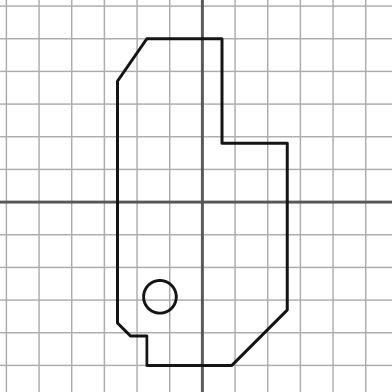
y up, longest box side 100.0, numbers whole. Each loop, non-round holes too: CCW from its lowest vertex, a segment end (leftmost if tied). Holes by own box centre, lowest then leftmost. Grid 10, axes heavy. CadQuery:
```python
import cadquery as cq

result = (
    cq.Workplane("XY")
    .moveTo(-17.0, -50.0)
    .lineTo(9.0, -50.0)
    .lineTo(26.0, -33.0)
    .lineTo(26.0, 18.0)
    .lineTo(6.0, 18.0)
    .lineTo(6.0, 50.0)
    .lineTo(-17.0, 50.0)
    .lineTo(-26.0, 37.0)
    .lineTo(-26.0, -37.0)
    .lineTo(-22.0, -41.0)
    .lineTo(-17.0, -41.0)
    .close()
    .moveTo(-13.0, -29.0)
    .circle(5.0)
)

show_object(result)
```